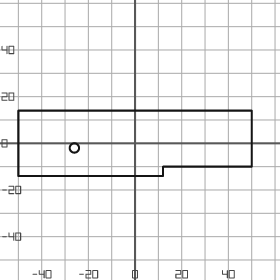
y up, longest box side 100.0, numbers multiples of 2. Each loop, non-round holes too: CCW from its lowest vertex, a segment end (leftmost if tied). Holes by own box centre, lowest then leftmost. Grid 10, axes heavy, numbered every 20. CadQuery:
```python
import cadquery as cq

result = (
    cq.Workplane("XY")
    .moveTo(-50.0, -14.0)
    .lineTo(12.0, -14.0)
    .lineTo(12.0, -10.0)
    .lineTo(50.0, -10.0)
    .lineTo(50.0, 14.0)
    .lineTo(-50.0, 14.0)
    .close()
    .moveTo(-26.0, -2.0)
    .circle(2.0)
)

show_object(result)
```